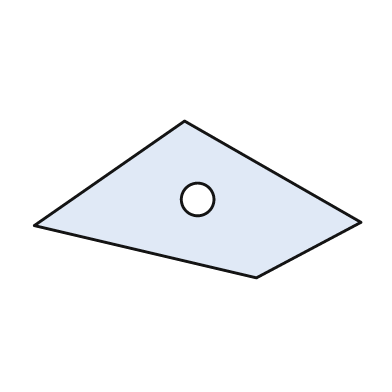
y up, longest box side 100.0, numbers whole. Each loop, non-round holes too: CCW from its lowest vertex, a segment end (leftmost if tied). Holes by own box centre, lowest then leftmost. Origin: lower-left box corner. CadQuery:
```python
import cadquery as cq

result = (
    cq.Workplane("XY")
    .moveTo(68.0, 0.0)
    .lineTo(100.0, 17.0)
    .lineTo(46.0, 48.0)
    .lineTo(0.0, 16.0)
    .close()
    .moveTo(50.0, 24.0)
    .circle(5.0)
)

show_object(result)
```